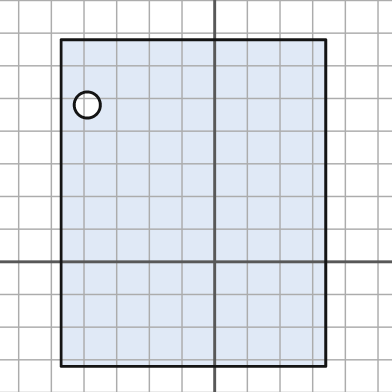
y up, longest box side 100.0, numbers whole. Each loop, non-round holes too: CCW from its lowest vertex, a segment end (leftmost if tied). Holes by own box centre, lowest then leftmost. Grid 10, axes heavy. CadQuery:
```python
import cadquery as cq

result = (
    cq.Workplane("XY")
    .moveTo(-47.0, -32.0)
    .lineTo(34.0, -32.0)
    .lineTo(34.0, 68.0)
    .lineTo(-47.0, 68.0)
    .close()
    .moveTo(-39.0, 48.0)
    .circle(4.0)
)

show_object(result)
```